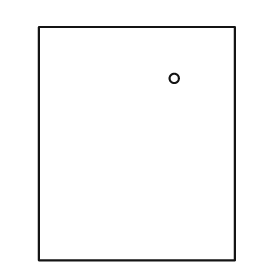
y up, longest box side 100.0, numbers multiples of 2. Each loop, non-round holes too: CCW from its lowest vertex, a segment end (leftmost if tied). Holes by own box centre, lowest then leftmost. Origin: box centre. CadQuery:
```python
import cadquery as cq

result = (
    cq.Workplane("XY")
    .moveTo(-42.0, -50.0)
    .lineTo(42.0, -50.0)
    .lineTo(42.0, 50.0)
    .lineTo(-42.0, 50.0)
    .close()
    .moveTo(16.0, 28.0)
    .circle(2.0)
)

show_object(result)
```